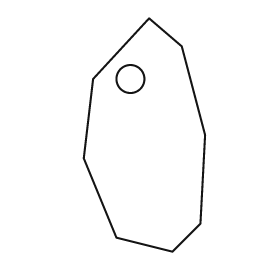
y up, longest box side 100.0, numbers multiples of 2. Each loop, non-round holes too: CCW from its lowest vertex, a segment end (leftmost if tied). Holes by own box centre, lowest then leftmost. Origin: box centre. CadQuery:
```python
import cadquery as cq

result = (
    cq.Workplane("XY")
    .moveTo(12.0, -50.0)
    .lineTo(24.0, -38.0)
    .lineTo(26.0, 0.0)
    .lineTo(16.0, 38.0)
    .lineTo(2.0, 50.0)
    .lineTo(-22.0, 24.0)
    .lineTo(-26.0, -10.0)
    .lineTo(-12.0, -44.0)
    .close()
    .moveTo(-6.0, 24.0)
    .circle(6.0)
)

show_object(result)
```